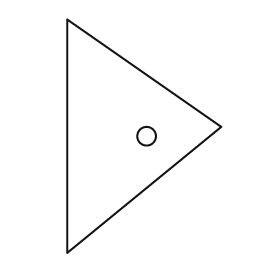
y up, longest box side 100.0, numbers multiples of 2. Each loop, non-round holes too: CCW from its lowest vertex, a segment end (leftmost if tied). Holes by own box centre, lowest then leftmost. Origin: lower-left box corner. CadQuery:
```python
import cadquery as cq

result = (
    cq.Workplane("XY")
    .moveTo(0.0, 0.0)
    .lineTo(66.0, 54.0)
    .lineTo(0.0, 100.0)
    .close()
    .moveTo(34.0, 50.0)
    .circle(4.0)
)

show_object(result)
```